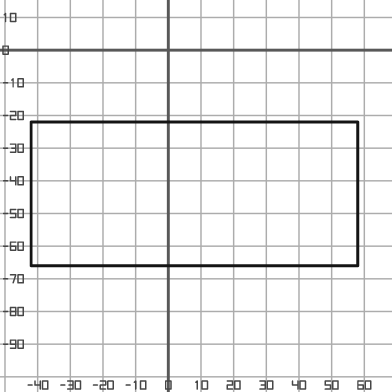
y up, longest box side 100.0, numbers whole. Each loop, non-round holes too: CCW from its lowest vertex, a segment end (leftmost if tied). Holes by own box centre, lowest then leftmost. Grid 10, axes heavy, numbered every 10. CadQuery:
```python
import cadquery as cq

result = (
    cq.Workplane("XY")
    .moveTo(-42.0, -66.0)
    .lineTo(58.0, -66.0)
    .lineTo(58.0, -22.0)
    .lineTo(-42.0, -22.0)
    .close()
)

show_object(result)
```